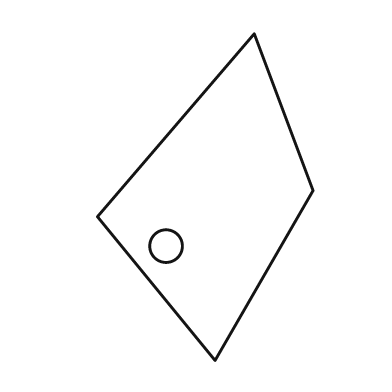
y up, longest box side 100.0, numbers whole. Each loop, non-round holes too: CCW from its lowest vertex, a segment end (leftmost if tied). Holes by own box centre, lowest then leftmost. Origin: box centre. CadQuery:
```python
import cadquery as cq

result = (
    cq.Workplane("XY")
    .moveTo(3.0, -50.0)
    .lineTo(33.0, 2.0)
    .lineTo(15.0, 50.0)
    .lineTo(-33.0, -6.0)
    .close()
    .moveTo(-12.0, -15.0)
    .circle(5.0)
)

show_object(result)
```